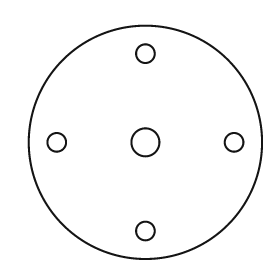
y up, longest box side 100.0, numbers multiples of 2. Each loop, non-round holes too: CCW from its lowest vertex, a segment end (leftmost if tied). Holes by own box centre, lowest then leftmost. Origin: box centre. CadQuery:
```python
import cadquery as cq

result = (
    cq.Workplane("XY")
    .moveTo(0.0, 0.0)
    .circle(50.0)
    .moveTo(0.0, -38.0)
    .circle(4.0)
    .moveTo(-38.0, 0.0)
    .circle(4.0)
    .moveTo(0.0, 0.0)
    .circle(6.0)
    .moveTo(38.0, 0.0)
    .circle(4.0)
    .moveTo(0.0, 38.0)
    .circle(4.0)
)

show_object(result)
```